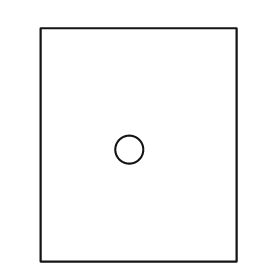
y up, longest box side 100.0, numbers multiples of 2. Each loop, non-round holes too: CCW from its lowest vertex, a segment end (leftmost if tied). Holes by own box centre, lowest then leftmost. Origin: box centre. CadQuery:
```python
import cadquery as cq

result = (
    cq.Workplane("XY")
    .moveTo(-42.0, -50.0)
    .lineTo(42.0, -50.0)
    .lineTo(42.0, 50.0)
    .lineTo(-42.0, 50.0)
    .close()
    .moveTo(-4.0, -2.0)
    .circle(6.0)
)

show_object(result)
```